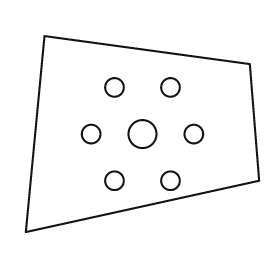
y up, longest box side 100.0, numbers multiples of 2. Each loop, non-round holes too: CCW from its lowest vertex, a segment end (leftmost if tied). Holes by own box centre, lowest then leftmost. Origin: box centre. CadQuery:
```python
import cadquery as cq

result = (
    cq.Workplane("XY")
    .moveTo(-50.0, -42.0)
    .lineTo(50.0, -20.0)
    .lineTo(46.0, 30.0)
    .lineTo(-42.0, 42.0)
    .close()
    .moveTo(-12.0, -20.0)
    .circle(4.0)
    .moveTo(12.0, -20.0)
    .circle(4.0)
    .moveTo(-22.0, 0.0)
    .circle(4.0)
    .moveTo(0.0, 0.0)
    .circle(6.0)
    .moveTo(22.0, 0.0)
    .circle(4.0)
    .moveTo(-12.0, 20.0)
    .circle(4.0)
    .moveTo(12.0, 20.0)
    .circle(4.0)
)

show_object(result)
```